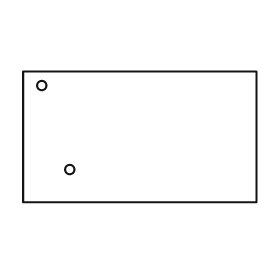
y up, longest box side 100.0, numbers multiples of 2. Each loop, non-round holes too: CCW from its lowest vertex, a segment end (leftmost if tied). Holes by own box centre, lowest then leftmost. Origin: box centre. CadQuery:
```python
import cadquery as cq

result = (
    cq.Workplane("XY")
    .moveTo(-50.0, -28.0)
    .lineTo(50.0, -28.0)
    .lineTo(50.0, 28.0)
    .lineTo(-50.0, 28.0)
    .close()
    .moveTo(-30.0, -14.0)
    .circle(2.0)
    .moveTo(-42.0, 22.0)
    .circle(2.0)
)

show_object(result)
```